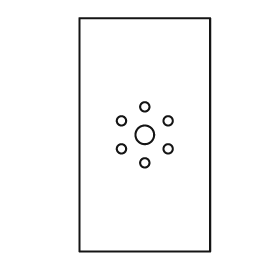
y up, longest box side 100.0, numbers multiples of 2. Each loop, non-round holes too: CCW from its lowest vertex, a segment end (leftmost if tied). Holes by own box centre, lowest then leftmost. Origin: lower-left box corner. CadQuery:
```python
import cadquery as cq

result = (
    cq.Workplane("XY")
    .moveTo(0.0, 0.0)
    .lineTo(56.0, 0.0)
    .lineTo(56.0, 100.0)
    .lineTo(0.0, 100.0)
    .close()
    .moveTo(28.0, 38.0)
    .circle(2.0)
    .moveTo(18.0, 44.0)
    .circle(2.0)
    .moveTo(38.0, 44.0)
    .circle(2.0)
    .moveTo(28.0, 50.0)
    .circle(4.0)
    .moveTo(18.0, 56.0)
    .circle(2.0)
    .moveTo(38.0, 56.0)
    .circle(2.0)
    .moveTo(28.0, 62.0)
    .circle(2.0)
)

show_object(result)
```